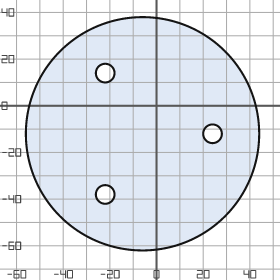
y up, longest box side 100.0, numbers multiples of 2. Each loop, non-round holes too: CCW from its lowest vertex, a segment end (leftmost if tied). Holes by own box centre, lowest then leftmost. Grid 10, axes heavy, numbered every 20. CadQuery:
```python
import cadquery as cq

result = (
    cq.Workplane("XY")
    .moveTo(-6.0, -12.0)
    .circle(50.0)
    .moveTo(-22.0, -38.0)
    .circle(4.0)
    .moveTo(24.0, -12.0)
    .circle(4.0)
    .moveTo(-22.0, 14.0)
    .circle(4.0)
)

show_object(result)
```